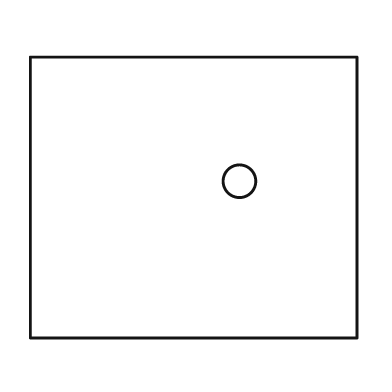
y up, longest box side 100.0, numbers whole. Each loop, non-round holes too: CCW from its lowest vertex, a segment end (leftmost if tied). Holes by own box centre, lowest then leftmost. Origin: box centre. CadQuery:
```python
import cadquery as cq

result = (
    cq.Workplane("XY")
    .moveTo(-50.0, -43.0)
    .lineTo(50.0, -43.0)
    .lineTo(50.0, 43.0)
    .lineTo(-50.0, 43.0)
    .close()
    .moveTo(14.0, 5.0)
    .circle(5.0)
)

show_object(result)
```